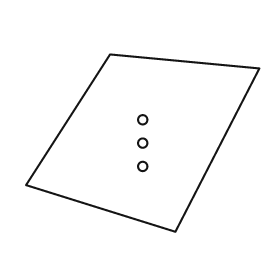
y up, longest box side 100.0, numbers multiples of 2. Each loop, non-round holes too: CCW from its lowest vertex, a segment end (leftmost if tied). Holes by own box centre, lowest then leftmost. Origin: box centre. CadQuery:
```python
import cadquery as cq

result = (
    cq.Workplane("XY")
    .moveTo(14.0, -38.0)
    .lineTo(50.0, 32.0)
    .lineTo(-14.0, 38.0)
    .lineTo(-50.0, -18.0)
    .close()
    .moveTo(0.0, -10.0)
    .circle(2.0)
    .moveTo(0.0, 0.0)
    .circle(2.0)
    .moveTo(0.0, 10.0)
    .circle(2.0)
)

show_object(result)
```